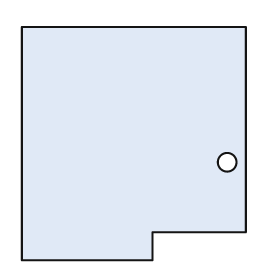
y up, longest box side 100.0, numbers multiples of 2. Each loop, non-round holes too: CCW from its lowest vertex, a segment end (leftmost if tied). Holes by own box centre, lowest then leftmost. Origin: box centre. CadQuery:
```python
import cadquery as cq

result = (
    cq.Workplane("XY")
    .moveTo(-48.0, -50.0)
    .lineTo(8.0, -50.0)
    .lineTo(8.0, -38.0)
    .lineTo(48.0, -38.0)
    .lineTo(48.0, 50.0)
    .lineTo(-48.0, 50.0)
    .close()
    .moveTo(40.0, -8.0)
    .circle(4.0)
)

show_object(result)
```